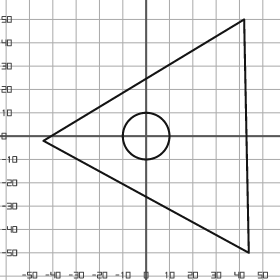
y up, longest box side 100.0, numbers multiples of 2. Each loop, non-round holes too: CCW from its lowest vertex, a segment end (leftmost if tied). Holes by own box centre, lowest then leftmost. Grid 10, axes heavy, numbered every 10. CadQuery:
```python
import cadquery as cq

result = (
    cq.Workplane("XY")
    .moveTo(44.0, -50.0)
    .lineTo(42.0, 50.0)
    .lineTo(-44.0, -2.0)
    .close()
    .moveTo(0.0, 0.0)
    .circle(10.0)
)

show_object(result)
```